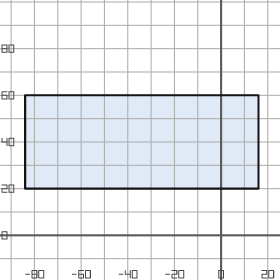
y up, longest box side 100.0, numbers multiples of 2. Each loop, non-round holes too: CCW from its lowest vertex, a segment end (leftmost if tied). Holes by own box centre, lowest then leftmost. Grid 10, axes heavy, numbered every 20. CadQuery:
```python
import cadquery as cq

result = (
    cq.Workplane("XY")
    .moveTo(-84.0, 20.0)
    .lineTo(16.0, 20.0)
    .lineTo(16.0, 60.0)
    .lineTo(-84.0, 60.0)
    .close()
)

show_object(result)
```